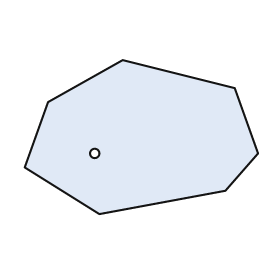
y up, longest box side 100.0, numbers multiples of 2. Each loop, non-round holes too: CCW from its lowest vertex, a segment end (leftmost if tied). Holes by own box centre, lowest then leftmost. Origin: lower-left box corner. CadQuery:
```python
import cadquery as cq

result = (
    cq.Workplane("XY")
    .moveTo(32.0, 0.0)
    .lineTo(86.0, 10.0)
    .lineTo(100.0, 26.0)
    .lineTo(90.0, 54.0)
    .lineTo(42.0, 66.0)
    .lineTo(10.0, 48.0)
    .lineTo(0.0, 20.0)
    .close()
    .moveTo(30.0, 26.0)
    .circle(2.0)
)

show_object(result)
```